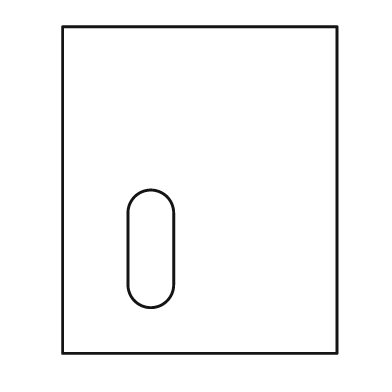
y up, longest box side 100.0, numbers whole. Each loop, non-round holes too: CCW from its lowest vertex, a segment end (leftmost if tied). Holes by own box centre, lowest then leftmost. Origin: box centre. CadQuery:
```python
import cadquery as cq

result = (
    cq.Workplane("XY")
    .moveTo(-42.0, -50.0)
    .lineTo(42.0, -50.0)
    .lineTo(42.0, 50.0)
    .lineTo(-42.0, 50.0)
    .close()
    .moveTo(-22.0, -29.0)
    .threePointArc((-15.0, -36.0), (-8.0, -29.0))
    .lineTo(-8.0, -7.0)
    .threePointArc((-15.0, 0.0), (-22.0, -7.0))
    .close()
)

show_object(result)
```